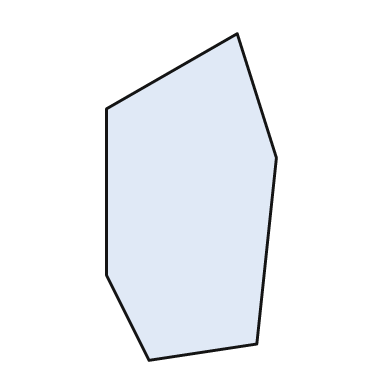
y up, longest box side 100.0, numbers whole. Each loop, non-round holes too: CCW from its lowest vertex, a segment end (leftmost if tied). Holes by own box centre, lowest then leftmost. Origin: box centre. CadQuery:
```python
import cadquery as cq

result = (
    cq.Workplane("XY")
    .moveTo(-13.0, -50.0)
    .lineTo(20.0, -45.0)
    .lineTo(26.0, 12.0)
    .lineTo(14.0, 50.0)
    .lineTo(-26.0, 27.0)
    .lineTo(-26.0, -24.0)
    .close()
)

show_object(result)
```